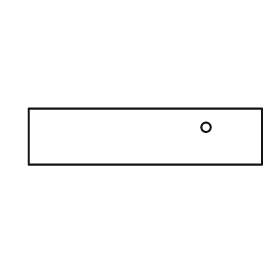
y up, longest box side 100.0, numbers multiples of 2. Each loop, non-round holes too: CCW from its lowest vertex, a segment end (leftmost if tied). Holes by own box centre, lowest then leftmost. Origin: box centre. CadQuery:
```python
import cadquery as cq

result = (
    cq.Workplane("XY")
    .moveTo(-50.0, -12.0)
    .lineTo(50.0, -12.0)
    .lineTo(50.0, 12.0)
    .lineTo(-50.0, 12.0)
    .close()
    .moveTo(26.0, 4.0)
    .circle(2.0)
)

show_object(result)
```